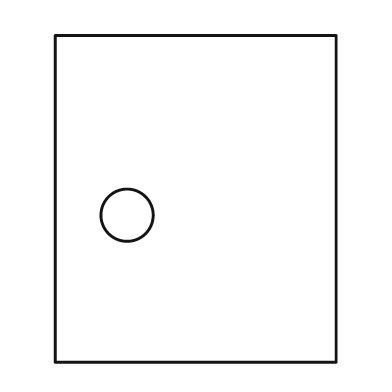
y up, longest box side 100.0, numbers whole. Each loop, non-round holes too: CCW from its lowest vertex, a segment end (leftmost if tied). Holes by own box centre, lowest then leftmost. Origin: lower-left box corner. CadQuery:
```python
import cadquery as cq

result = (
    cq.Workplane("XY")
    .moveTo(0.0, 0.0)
    .lineTo(86.0, 0.0)
    .lineTo(86.0, 100.0)
    .lineTo(0.0, 100.0)
    .close()
    .moveTo(22.0, 45.0)
    .circle(8.0)
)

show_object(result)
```